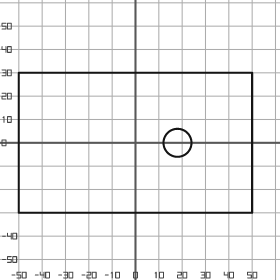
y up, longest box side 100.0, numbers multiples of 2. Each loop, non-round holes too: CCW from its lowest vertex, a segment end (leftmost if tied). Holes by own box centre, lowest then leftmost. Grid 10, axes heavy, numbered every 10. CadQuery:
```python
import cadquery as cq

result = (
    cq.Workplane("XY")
    .moveTo(-50.0, -30.0)
    .lineTo(50.0, -30.0)
    .lineTo(50.0, 30.0)
    .lineTo(-50.0, 30.0)
    .close()
    .moveTo(18.0, 0.0)
    .circle(6.0)
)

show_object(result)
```